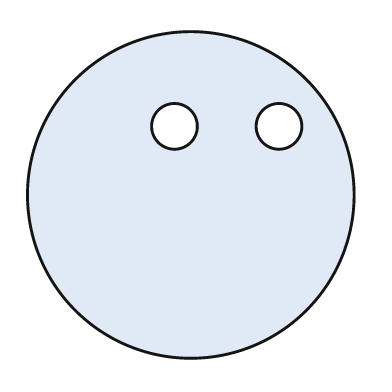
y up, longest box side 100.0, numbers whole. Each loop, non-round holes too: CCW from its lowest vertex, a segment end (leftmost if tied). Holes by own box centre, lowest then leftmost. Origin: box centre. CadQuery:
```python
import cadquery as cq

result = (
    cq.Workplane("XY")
    .moveTo(0.0, 0.0)
    .circle(50.0)
    .moveTo(-5.0, 21.0)
    .circle(7.0)
    .moveTo(27.0, 21.0)
    .circle(7.0)
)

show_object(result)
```